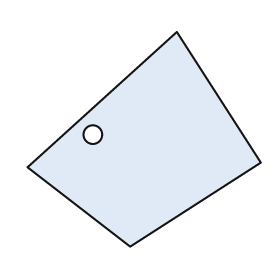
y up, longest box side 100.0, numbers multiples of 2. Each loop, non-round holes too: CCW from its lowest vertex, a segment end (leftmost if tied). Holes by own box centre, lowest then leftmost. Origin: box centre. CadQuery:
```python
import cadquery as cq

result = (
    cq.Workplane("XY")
    .moveTo(-6.0, -46.0)
    .lineTo(50.0, -10.0)
    .lineTo(14.0, 46.0)
    .lineTo(-50.0, -12.0)
    .close()
    .moveTo(-22.0, 2.0)
    .circle(4.0)
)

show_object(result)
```